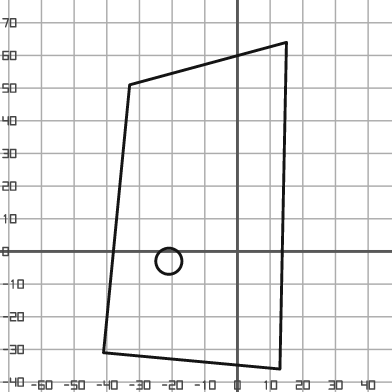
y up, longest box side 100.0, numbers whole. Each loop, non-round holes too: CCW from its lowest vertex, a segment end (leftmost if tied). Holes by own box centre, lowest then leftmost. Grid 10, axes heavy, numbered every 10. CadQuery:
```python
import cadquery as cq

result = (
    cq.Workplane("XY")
    .moveTo(13.0, -36.0)
    .lineTo(15.0, 64.0)
    .lineTo(-33.0, 51.0)
    .lineTo(-41.0, -31.0)
    .close()
    .moveTo(-21.0, -3.0)
    .circle(4.0)
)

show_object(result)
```